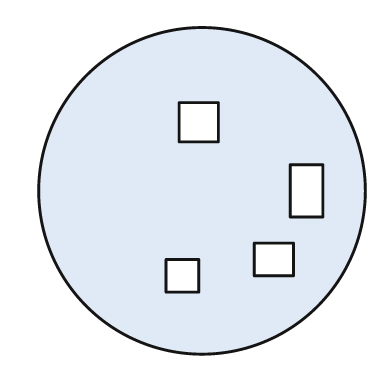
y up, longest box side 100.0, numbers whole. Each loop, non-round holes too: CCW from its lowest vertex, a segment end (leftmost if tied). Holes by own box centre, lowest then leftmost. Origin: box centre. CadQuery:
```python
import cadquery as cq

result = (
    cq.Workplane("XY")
    .moveTo(0.0, 0.0)
    .circle(50.0)
    .moveTo(-11.0, -31.0)
    .lineTo(-1.0, -31.0)
    .lineTo(-1.0, -21.0)
    .lineTo(-11.0, -21.0)
    .close()
    .moveTo(16.0, -26.0)
    .lineTo(28.0, -26.0)
    .lineTo(28.0, -16.0)
    .lineTo(16.0, -16.0)
    .close()
    .moveTo(27.0, -8.0)
    .lineTo(37.0, -8.0)
    .lineTo(37.0, 8.0)
    .lineTo(27.0, 8.0)
    .close()
    .moveTo(-7.0, 15.0)
    .lineTo(5.0, 15.0)
    .lineTo(5.0, 27.0)
    .lineTo(-7.0, 27.0)
    .close()
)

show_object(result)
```